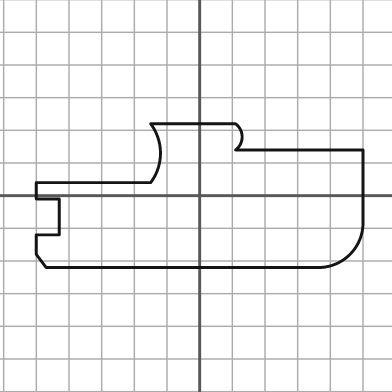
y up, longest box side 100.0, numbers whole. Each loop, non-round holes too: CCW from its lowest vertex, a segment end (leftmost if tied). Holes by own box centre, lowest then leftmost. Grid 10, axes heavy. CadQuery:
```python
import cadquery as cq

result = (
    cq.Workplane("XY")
    .moveTo(-47.0, -22.0)
    .lineTo(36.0, -22.0)
    .threePointArc((46.0, -18.0), (50.0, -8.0))
    .lineTo(50.0, 14.0)
    .lineTo(11.0, 14.0)
    .threePointArc((13.0, 18.0), (11.0, 22.0))
    .lineTo(-15.0, 22.0)
    .threePointArc((-12.0, 13.0), (-15.0, 4.0))
    .lineTo(-50.0, 4.0)
    .lineTo(-50.0, -1.0)
    .lineTo(-43.0, -1.0)
    .lineTo(-43.0, -12.0)
    .lineTo(-50.0, -12.0)
    .lineTo(-50.0, -18.0)
    .close()
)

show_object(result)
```